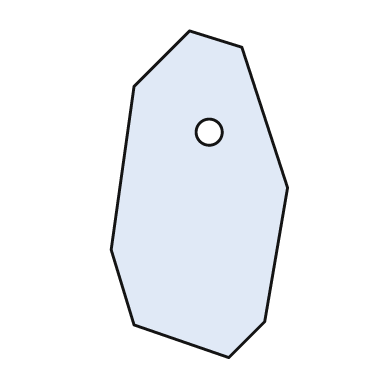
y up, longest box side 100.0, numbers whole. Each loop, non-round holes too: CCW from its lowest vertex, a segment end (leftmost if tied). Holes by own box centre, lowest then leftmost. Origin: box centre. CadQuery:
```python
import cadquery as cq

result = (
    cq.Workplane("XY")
    .moveTo(9.0, -50.0)
    .lineTo(20.0, -39.0)
    .lineTo(27.0, 2.0)
    .lineTo(13.0, 45.0)
    .lineTo(-3.0, 50.0)
    .lineTo(-20.0, 33.0)
    .lineTo(-27.0, -17.0)
    .lineTo(-20.0, -40.0)
    .close()
    .moveTo(3.0, 19.0)
    .circle(4.0)
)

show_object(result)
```